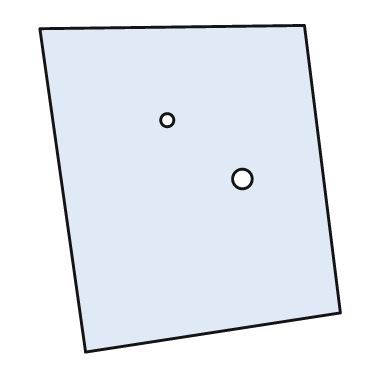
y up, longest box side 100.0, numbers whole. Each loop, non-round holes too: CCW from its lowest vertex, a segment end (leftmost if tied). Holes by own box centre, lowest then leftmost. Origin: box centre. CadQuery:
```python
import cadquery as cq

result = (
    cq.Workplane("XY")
    .moveTo(-32.0, -50.0)
    .lineTo(46.0, -38.0)
    .lineTo(35.0, 50.0)
    .lineTo(-46.0, 49.0)
    .close()
    .moveTo(16.0, 3.0)
    .circle(3.0)
    .moveTo(-7.0, 21.0)
    .circle(2.0)
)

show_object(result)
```